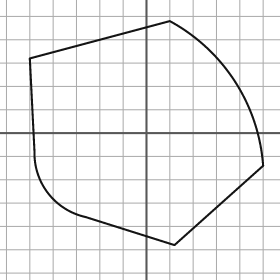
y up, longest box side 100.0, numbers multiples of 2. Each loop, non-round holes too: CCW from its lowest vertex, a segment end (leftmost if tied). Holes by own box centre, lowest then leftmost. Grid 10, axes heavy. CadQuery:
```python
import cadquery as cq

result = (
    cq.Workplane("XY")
    .moveTo(12.0, -48.0)
    .lineTo(50.0, -14.0)
    .threePointArc((38.0, 22.0), (10.0, 48.0))
    .lineTo(-50.0, 32.0)
    .lineTo(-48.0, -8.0)
    .threePointArc((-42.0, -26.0), (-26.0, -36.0))
    .close()
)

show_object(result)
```